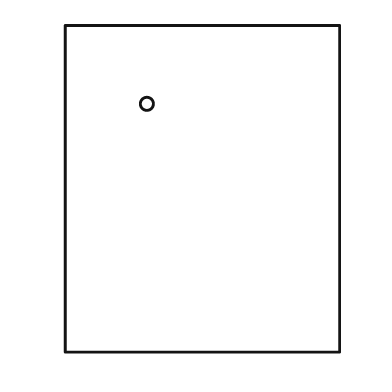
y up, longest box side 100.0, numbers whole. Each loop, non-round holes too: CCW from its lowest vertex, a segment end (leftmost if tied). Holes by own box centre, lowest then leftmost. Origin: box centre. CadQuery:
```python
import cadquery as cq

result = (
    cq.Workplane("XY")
    .moveTo(-42.0, -50.0)
    .lineTo(42.0, -50.0)
    .lineTo(42.0, 50.0)
    .lineTo(-42.0, 50.0)
    .close()
    .moveTo(-17.0, 26.0)
    .circle(2.0)
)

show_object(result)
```